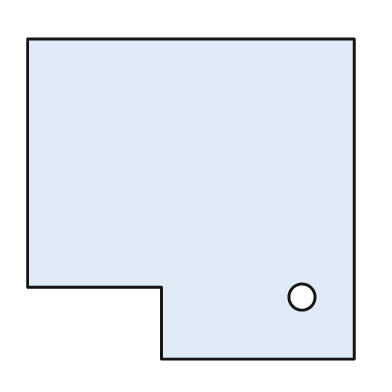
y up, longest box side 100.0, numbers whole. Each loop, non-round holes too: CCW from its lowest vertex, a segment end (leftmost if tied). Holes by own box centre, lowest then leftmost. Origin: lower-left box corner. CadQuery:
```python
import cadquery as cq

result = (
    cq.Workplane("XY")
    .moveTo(41.0, 0.0)
    .lineTo(100.0, 0.0)
    .lineTo(100.0, 98.0)
    .lineTo(0.0, 98.0)
    .lineTo(0.0, 22.0)
    .lineTo(41.0, 22.0)
    .close()
    .moveTo(84.0, 19.0)
    .circle(4.0)
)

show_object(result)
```